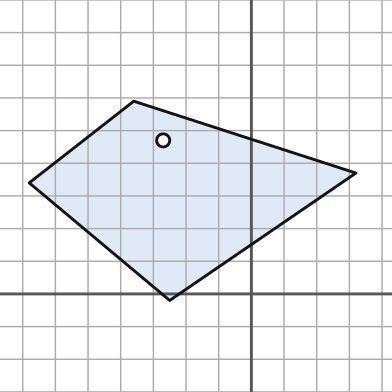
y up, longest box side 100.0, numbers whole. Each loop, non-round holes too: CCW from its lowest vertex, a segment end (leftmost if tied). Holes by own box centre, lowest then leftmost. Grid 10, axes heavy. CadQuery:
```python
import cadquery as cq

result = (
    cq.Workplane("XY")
    .moveTo(-25.0, -2.0)
    .lineTo(32.0, 37.0)
    .lineTo(-36.0, 59.0)
    .lineTo(-68.0, 34.0)
    .close()
    .moveTo(-27.0, 47.0)
    .circle(2.0)
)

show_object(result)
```